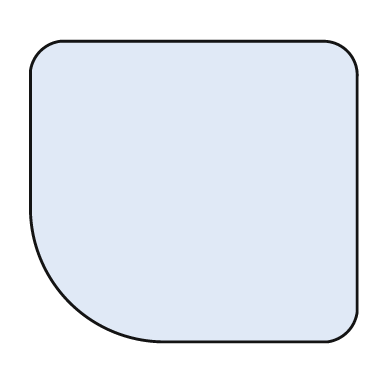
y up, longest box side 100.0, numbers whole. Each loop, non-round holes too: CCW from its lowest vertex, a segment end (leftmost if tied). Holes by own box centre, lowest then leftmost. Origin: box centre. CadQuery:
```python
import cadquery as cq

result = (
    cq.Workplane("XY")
    .moveTo(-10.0, -46.0)
    .lineTo(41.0, -46.0)
    .threePointArc((47.0, -43.0), (50.0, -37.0))
    .lineTo(50.0, 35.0)
    .threePointArc((47.0, 43.0), (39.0, 46.0))
    .lineTo(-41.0, 46.0)
    .threePointArc((-47.0, 43.0), (-50.0, 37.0))
    .lineTo(-50.0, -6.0)
    .threePointArc((-38.0, -34.0), (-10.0, -46.0))
    .close()
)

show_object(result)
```